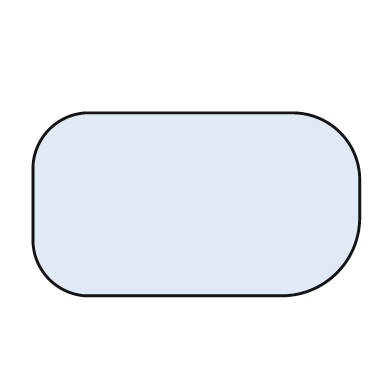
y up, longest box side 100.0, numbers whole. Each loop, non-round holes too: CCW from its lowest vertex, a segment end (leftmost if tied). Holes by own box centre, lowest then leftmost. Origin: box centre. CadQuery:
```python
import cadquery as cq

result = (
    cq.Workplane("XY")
    .moveTo(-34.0, -28.0)
    .lineTo(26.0, -28.0)
    .threePointArc((43.0, -21.0), (50.0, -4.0))
    .lineTo(50.0, 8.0)
    .threePointArc((44.0, 22.0), (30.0, 28.0))
    .lineTo(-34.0, 28.0)
    .threePointArc((-45.0, 23.0), (-50.0, 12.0))
    .lineTo(-50.0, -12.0)
    .threePointArc((-45.0, -23.0), (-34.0, -28.0))
    .close()
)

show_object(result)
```